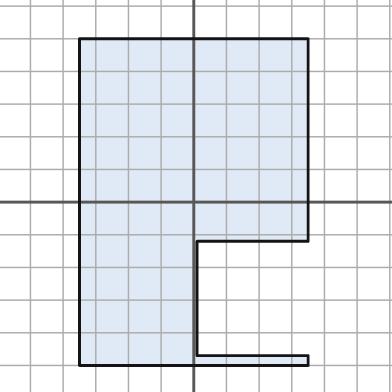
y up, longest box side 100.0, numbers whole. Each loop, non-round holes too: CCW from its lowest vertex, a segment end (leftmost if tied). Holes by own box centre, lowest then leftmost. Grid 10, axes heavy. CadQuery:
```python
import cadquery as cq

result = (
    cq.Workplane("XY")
    .moveTo(-35.0, -50.0)
    .lineTo(35.0, -50.0)
    .lineTo(35.0, -47.0)
    .lineTo(1.0, -47.0)
    .lineTo(1.0, -12.0)
    .lineTo(35.0, -12.0)
    .lineTo(35.0, 50.0)
    .lineTo(-35.0, 50.0)
    .close()
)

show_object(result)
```